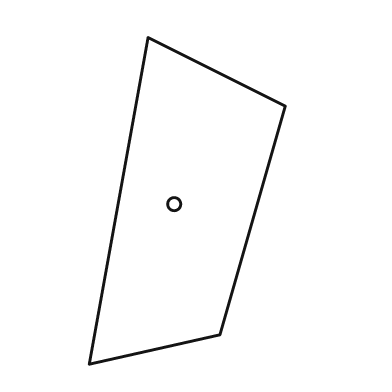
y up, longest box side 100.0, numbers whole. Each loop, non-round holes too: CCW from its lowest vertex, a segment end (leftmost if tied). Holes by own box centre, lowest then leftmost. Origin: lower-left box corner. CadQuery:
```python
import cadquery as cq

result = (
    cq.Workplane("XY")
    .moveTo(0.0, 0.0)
    .lineTo(40.0, 9.0)
    .lineTo(60.0, 79.0)
    .lineTo(18.0, 100.0)
    .close()
    .moveTo(26.0, 49.0)
    .circle(2.0)
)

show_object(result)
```